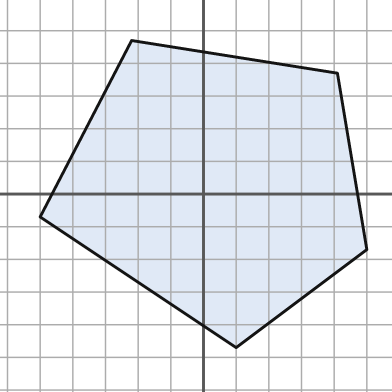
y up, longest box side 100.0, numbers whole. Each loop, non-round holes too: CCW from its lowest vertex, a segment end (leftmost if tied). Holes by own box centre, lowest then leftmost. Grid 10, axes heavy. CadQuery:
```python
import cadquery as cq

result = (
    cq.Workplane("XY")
    .moveTo(10.0, -47.0)
    .lineTo(50.0, -17.0)
    .lineTo(41.0, 37.0)
    .lineTo(-22.0, 47.0)
    .lineTo(-50.0, -7.0)
    .close()
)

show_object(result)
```